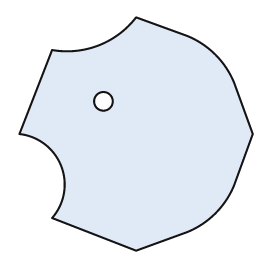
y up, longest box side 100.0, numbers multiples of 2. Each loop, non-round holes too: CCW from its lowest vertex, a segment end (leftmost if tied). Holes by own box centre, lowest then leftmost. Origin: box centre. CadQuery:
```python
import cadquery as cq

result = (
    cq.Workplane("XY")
    .moveTo(0.0, -50.0)
    .lineTo(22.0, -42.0)
    .threePointArc((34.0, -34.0), (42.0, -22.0))
    .lineTo(50.0, 0.0)
    .lineTo(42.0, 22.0)
    .threePointArc((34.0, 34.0), (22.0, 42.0))
    .lineTo(0.0, 50.0)
    .threePointArc((-16.0, 38.0), (-36.0, 36.0))
    .lineTo(-50.0, 0.0)
    .threePointArc((-32.0, -14.0), (-36.0, -36.0))
    .close()
    .moveTo(-14.0, 14.0)
    .circle(4.0)
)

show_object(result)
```